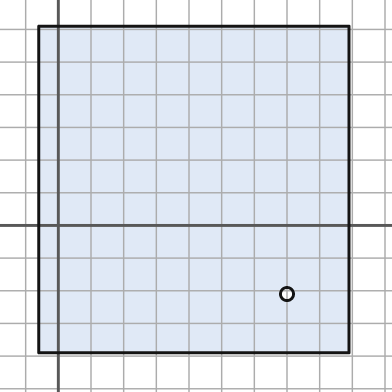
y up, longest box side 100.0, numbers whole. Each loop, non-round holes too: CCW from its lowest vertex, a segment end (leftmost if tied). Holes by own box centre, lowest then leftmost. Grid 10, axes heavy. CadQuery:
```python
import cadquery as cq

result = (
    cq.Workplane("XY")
    .moveTo(-6.0, -39.0)
    .lineTo(89.0, -39.0)
    .lineTo(89.0, 61.0)
    .lineTo(-6.0, 61.0)
    .close()
    .moveTo(70.0, -21.0)
    .circle(2.0)
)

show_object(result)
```